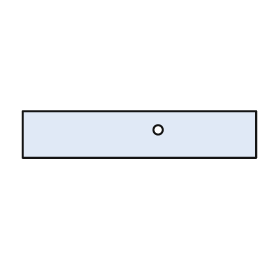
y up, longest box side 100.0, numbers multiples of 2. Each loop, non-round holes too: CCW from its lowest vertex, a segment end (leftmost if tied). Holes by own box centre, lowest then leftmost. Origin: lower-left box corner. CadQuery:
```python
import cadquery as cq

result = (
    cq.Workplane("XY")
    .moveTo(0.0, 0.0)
    .lineTo(100.0, 0.0)
    .lineTo(100.0, 20.0)
    .lineTo(0.0, 20.0)
    .close()
    .moveTo(58.0, 12.0)
    .circle(2.0)
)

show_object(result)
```